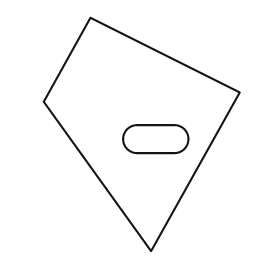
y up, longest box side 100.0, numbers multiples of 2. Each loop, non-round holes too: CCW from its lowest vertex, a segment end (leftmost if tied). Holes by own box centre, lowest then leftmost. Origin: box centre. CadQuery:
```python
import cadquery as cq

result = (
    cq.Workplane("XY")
    .moveTo(4.0, -50.0)
    .lineTo(42.0, 18.0)
    .lineTo(-22.0, 50.0)
    .lineTo(-42.0, 14.0)
    .close()
    .moveTo(-2.0, -8.0)
    .lineTo(14.0, -8.0)
    .threePointArc((20.0, -2.0), (14.0, 4.0))
    .lineTo(-2.0, 4.0)
    .threePointArc((-8.0, -2.0), (-2.0, -8.0))
    .close()
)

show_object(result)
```